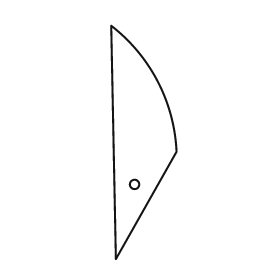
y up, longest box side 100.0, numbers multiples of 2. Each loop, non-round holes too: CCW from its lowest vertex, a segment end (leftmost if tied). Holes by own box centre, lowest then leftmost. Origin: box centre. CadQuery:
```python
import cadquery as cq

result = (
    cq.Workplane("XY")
    .moveTo(-12.0, -50.0)
    .lineTo(14.0, -4.0)
    .threePointArc((6.0, 26.0), (-14.0, 50.0))
    .close()
    .moveTo(-4.0, -18.0)
    .circle(2.0)
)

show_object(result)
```